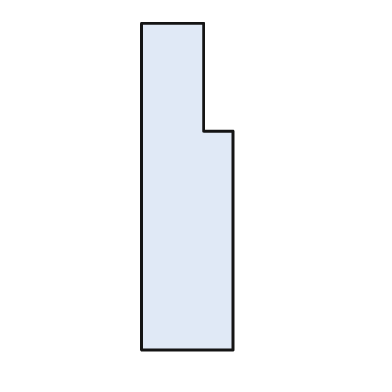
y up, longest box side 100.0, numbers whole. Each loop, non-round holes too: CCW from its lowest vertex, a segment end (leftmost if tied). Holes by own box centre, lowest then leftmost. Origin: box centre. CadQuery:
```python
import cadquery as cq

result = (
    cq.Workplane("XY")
    .moveTo(-14.0, -50.0)
    .lineTo(14.0, -50.0)
    .lineTo(14.0, 17.0)
    .lineTo(5.0, 17.0)
    .lineTo(5.0, 50.0)
    .lineTo(-14.0, 50.0)
    .close()
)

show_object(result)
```